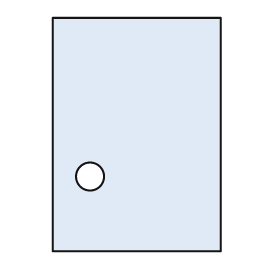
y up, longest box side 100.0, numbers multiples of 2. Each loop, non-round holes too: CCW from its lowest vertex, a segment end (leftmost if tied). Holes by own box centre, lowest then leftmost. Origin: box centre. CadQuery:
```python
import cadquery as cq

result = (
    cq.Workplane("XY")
    .moveTo(-36.0, -50.0)
    .lineTo(36.0, -50.0)
    .lineTo(36.0, 50.0)
    .lineTo(-36.0, 50.0)
    .close()
    .moveTo(-20.0, -18.0)
    .circle(6.0)
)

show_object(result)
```